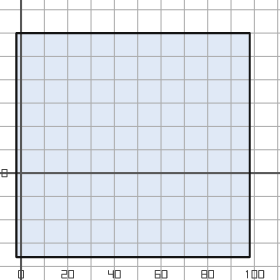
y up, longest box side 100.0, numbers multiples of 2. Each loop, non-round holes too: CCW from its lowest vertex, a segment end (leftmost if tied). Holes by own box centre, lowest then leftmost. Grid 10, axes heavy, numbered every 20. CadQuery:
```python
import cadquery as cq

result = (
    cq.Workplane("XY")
    .moveTo(-2.0, -36.0)
    .lineTo(98.0, -36.0)
    .lineTo(98.0, 60.0)
    .lineTo(-2.0, 60.0)
    .close()
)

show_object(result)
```